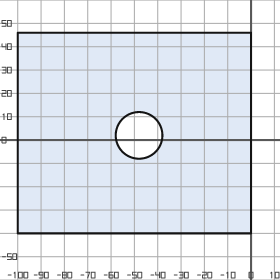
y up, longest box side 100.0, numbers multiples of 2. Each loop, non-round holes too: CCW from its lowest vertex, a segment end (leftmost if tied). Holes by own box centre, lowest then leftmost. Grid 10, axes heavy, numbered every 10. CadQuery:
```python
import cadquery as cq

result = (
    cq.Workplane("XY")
    .moveTo(-100.0, -40.0)
    .lineTo(0.0, -40.0)
    .lineTo(0.0, 46.0)
    .lineTo(-100.0, 46.0)
    .close()
    .moveTo(-48.0, 2.0)
    .circle(10.0)
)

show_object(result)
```